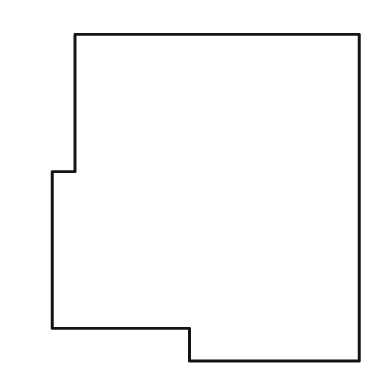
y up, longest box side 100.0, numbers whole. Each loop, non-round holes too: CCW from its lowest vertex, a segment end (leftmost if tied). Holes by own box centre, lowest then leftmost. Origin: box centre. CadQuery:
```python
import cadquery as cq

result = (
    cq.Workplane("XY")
    .moveTo(-5.0, -50.0)
    .lineTo(47.0, -50.0)
    .lineTo(47.0, 50.0)
    .lineTo(-40.0, 50.0)
    .lineTo(-40.0, 8.0)
    .lineTo(-47.0, 8.0)
    .lineTo(-47.0, -40.0)
    .lineTo(-5.0, -40.0)
    .close()
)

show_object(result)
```